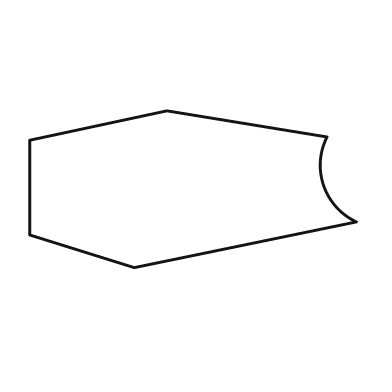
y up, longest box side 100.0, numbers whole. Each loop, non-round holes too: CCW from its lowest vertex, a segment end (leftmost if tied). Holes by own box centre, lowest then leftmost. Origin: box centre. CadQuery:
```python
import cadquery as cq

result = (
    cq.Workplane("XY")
    .moveTo(-18.0, -24.0)
    .lineTo(50.0, -10.0)
    .threePointArc((40.0, 1.0), (41.0, 16.0))
    .lineTo(-8.0, 24.0)
    .lineTo(-50.0, 15.0)
    .lineTo(-50.0, -14.0)
    .close()
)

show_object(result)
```